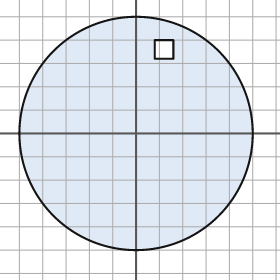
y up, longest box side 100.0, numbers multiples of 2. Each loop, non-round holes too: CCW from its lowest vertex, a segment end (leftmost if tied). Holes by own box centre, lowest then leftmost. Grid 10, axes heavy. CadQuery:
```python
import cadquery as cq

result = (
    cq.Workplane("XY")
    .moveTo(0.0, 0.0)
    .circle(50.0)
    .moveTo(8.0, 32.0)
    .lineTo(16.0, 32.0)
    .lineTo(16.0, 40.0)
    .lineTo(8.0, 40.0)
    .close()
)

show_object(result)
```